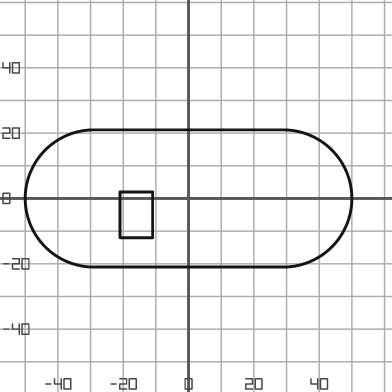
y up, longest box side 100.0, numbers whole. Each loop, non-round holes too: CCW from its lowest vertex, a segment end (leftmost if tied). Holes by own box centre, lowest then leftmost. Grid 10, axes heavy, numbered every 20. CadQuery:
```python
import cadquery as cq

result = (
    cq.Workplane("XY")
    .moveTo(-29.0, -21.0)
    .lineTo(29.0, -21.0)
    .threePointArc((50.0, 0.0), (29.0, 21.0))
    .lineTo(-29.0, 21.0)
    .threePointArc((-50.0, 0.0), (-29.0, -21.0))
    .close()
    .moveTo(-21.0, -12.0)
    .lineTo(-11.0, -12.0)
    .lineTo(-11.0, 2.0)
    .lineTo(-21.0, 2.0)
    .close()
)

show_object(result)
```